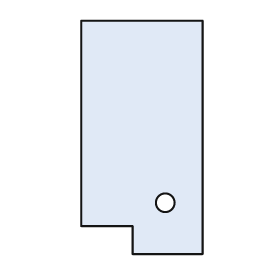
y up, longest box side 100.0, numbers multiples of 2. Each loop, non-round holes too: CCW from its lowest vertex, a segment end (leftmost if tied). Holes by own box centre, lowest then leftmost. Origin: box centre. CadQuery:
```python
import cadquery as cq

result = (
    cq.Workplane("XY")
    .moveTo(-4.0, -50.0)
    .lineTo(26.0, -50.0)
    .lineTo(26.0, 50.0)
    .lineTo(-26.0, 50.0)
    .lineTo(-26.0, -38.0)
    .lineTo(-4.0, -38.0)
    .close()
    .moveTo(10.0, -28.0)
    .circle(4.0)
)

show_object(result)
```